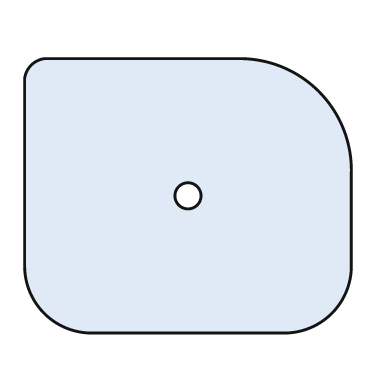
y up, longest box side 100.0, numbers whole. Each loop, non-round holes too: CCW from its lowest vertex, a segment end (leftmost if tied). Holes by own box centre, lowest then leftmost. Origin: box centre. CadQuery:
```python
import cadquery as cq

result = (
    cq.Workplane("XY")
    .moveTo(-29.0, -42.0)
    .lineTo(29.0, -42.0)
    .threePointArc((44.0, -36.0), (50.0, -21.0))
    .lineTo(50.0, 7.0)
    .threePointArc((40.0, 32.0), (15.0, 42.0))
    .lineTo(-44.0, 42.0)
    .threePointArc((-48.0, 40.0), (-50.0, 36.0))
    .lineTo(-50.0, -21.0)
    .threePointArc((-44.0, -36.0), (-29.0, -42.0))
    .close()
    .moveTo(0.0, 0.0)
    .circle(4.0)
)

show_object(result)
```